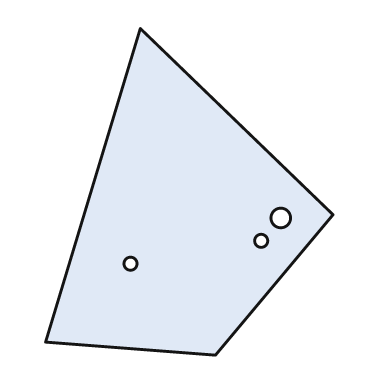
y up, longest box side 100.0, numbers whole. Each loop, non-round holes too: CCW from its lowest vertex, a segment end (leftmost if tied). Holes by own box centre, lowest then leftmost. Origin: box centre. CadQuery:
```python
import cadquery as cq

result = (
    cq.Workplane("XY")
    .moveTo(8.0, -50.0)
    .lineTo(44.0, -7.0)
    .lineTo(-15.0, 50.0)
    .lineTo(-44.0, -46.0)
    .close()
    .moveTo(-18.0, -22.0)
    .circle(2.0)
    .moveTo(22.0, -15.0)
    .circle(2.0)
    .moveTo(28.0, -8.0)
    .circle(3.0)
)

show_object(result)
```